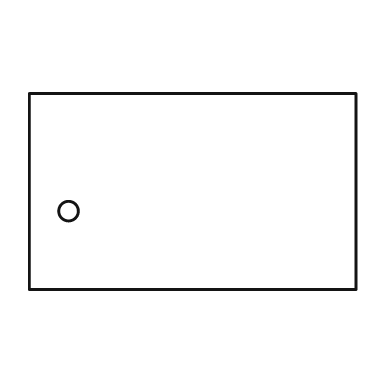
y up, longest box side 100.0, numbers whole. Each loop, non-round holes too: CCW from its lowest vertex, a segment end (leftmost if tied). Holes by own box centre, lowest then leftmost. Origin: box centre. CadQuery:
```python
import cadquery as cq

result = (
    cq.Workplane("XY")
    .moveTo(-50.0, -30.0)
    .lineTo(50.0, -30.0)
    .lineTo(50.0, 30.0)
    .lineTo(-50.0, 30.0)
    .close()
    .moveTo(-38.0, -6.0)
    .circle(3.0)
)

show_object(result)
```